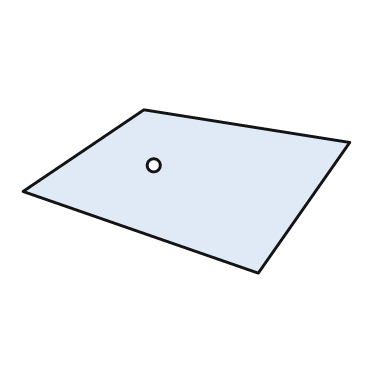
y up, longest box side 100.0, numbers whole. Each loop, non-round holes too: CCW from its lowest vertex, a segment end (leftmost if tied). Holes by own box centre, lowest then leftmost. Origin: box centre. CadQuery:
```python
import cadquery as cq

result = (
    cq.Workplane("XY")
    .moveTo(22.0, -25.0)
    .lineTo(50.0, 15.0)
    .lineTo(-13.0, 25.0)
    .lineTo(-50.0, 0.0)
    .close()
    .moveTo(-10.0, 8.0)
    .circle(2.0)
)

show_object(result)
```